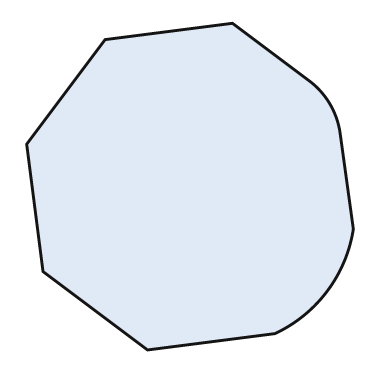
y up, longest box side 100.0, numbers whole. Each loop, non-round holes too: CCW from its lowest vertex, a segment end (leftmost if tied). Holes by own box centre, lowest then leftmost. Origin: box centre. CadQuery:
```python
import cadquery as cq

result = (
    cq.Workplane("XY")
    .moveTo(-13.0, -50.0)
    .lineTo(26.0, -45.0)
    .threePointArc((42.0, -32.0), (50.0, -13.0))
    .lineTo(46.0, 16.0)
    .threePointArc((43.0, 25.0), (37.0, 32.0))
    .lineTo(13.0, 50.0)
    .lineTo(-26.0, 45.0)
    .lineTo(-50.0, 13.0)
    .lineTo(-45.0, -26.0)
    .close()
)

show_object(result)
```